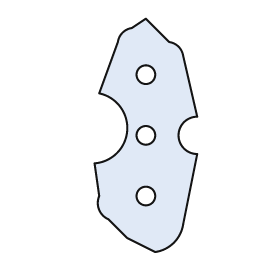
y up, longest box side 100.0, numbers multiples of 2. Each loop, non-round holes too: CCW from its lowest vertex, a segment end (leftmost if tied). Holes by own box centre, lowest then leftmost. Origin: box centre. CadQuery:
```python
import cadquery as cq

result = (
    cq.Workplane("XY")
    .moveTo(4.0, -50.0)
    .threePointArc((12.0, -46.0), (16.0, -38.0))
    .lineTo(22.0, -8.0)
    .threePointArc((14.0, 0.0), (22.0, 8.0))
    .lineTo(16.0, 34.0)
    .threePointArc((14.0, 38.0), (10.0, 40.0))
    .lineTo(0.0, 50.0)
    .lineTo(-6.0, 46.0)
    .threePointArc((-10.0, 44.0), (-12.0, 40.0))
    .lineTo(-20.0, 18.0)
    .threePointArc((-8.0, 2.0), (-22.0, -12.0))
    .lineTo(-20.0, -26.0)
    .threePointArc((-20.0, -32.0), (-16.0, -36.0))
    .lineTo(-8.0, -44.0)
    .close()
    .moveTo(0.0, -26.0)
    .circle(4.0)
    .moveTo(0.0, 0.0)
    .circle(4.0)
    .moveTo(0.0, 26.0)
    .circle(4.0)
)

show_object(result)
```